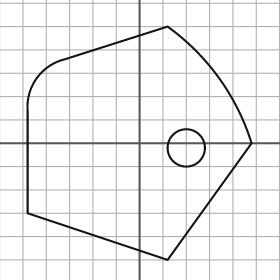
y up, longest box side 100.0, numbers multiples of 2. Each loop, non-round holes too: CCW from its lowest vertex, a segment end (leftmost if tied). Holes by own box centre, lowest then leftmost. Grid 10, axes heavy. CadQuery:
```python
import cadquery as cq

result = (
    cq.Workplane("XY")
    .moveTo(12.0, -50.0)
    .lineTo(48.0, 0.0)
    .threePointArc((34.0, 28.0), (12.0, 50.0))
    .lineTo(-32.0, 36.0)
    .threePointArc((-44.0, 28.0), (-48.0, 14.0))
    .lineTo(-48.0, -30.0)
    .close()
    .moveTo(20.0, -2.0)
    .circle(8.0)
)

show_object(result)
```